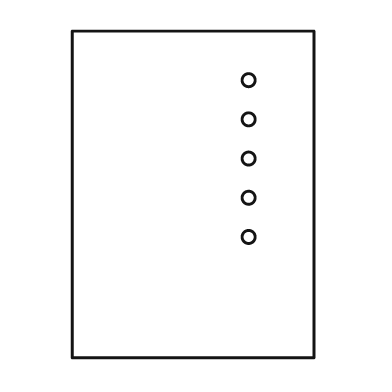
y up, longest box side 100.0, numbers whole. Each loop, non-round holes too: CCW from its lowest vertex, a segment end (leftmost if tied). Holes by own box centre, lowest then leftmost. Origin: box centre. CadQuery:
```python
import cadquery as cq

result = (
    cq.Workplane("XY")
    .moveTo(-37.0, -50.0)
    .lineTo(37.0, -50.0)
    .lineTo(37.0, 50.0)
    .lineTo(-37.0, 50.0)
    .close()
    .moveTo(17.0, -13.0)
    .circle(2.0)
    .moveTo(17.0, -1.0)
    .circle(2.0)
    .moveTo(17.0, 11.0)
    .circle(2.0)
    .moveTo(17.0, 23.0)
    .circle(2.0)
    .moveTo(17.0, 35.0)
    .circle(2.0)
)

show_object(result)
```